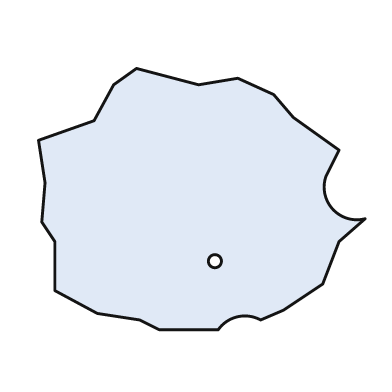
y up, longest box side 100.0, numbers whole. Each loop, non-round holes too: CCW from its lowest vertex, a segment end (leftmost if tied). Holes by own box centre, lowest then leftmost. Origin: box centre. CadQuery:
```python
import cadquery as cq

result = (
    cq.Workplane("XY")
    .moveTo(-13.0, -40.0)
    .lineTo(5.0, -40.0)
    .threePointArc((11.0, -36.0), (18.0, -37.0))
    .lineTo(25.0, -34.0)
    .lineTo(37.0, -26.0)
    .lineTo(42.0, -13.0)
    .lineTo(50.0, -6.0)
    .threePointArc((40.0, -3.0), (38.0, 7.0))
    .lineTo(42.0, 15.0)
    .lineTo(28.0, 25.0)
    .lineTo(22.0, 32.0)
    .lineTo(11.0, 37.0)
    .lineTo(-1.0, 35.0)
    .lineTo(-20.0, 40.0)
    .lineTo(-27.0, 35.0)
    .lineTo(-33.0, 24.0)
    .lineTo(-50.0, 18.0)
    .lineTo(-48.0, 5.0)
    .lineTo(-49.0, -7.0)
    .lineTo(-45.0, -13.0)
    .lineTo(-45.0, -28.0)
    .lineTo(-32.0, -35.0)
    .lineTo(-19.0, -37.0)
    .close()
    .moveTo(4.0, -19.0)
    .circle(2.0)
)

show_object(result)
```